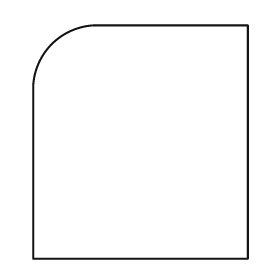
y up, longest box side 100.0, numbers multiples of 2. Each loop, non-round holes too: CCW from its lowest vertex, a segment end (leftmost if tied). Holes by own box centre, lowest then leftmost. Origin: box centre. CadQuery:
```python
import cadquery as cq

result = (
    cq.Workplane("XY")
    .moveTo(-46.0, -50.0)
    .lineTo(46.0, -50.0)
    .lineTo(46.0, 50.0)
    .lineTo(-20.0, 50.0)
    .threePointArc((-38.0, 42.0), (-46.0, 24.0))
    .close()
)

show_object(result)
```